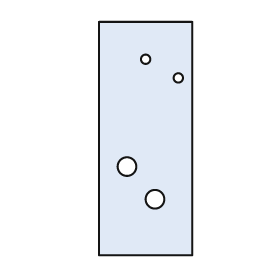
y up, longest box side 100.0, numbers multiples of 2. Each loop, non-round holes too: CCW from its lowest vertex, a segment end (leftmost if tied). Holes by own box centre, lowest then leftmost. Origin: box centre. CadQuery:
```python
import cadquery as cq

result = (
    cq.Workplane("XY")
    .moveTo(-20.0, -50.0)
    .lineTo(20.0, -50.0)
    .lineTo(20.0, 50.0)
    .lineTo(-20.0, 50.0)
    .close()
    .moveTo(4.0, -26.0)
    .circle(4.0)
    .moveTo(-8.0, -12.0)
    .circle(4.0)
    .moveTo(14.0, 26.0)
    .circle(2.0)
    .moveTo(0.0, 34.0)
    .circle(2.0)
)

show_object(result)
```